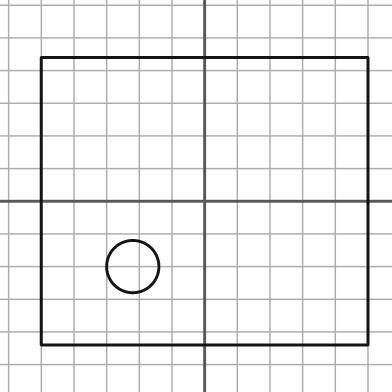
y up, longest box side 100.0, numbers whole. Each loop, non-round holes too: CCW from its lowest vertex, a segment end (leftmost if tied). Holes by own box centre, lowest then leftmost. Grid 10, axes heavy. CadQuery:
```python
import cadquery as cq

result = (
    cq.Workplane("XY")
    .moveTo(-50.0, -44.0)
    .lineTo(50.0, -44.0)
    .lineTo(50.0, 44.0)
    .lineTo(-50.0, 44.0)
    .close()
    .moveTo(-22.0, -20.0)
    .circle(8.0)
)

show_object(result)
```